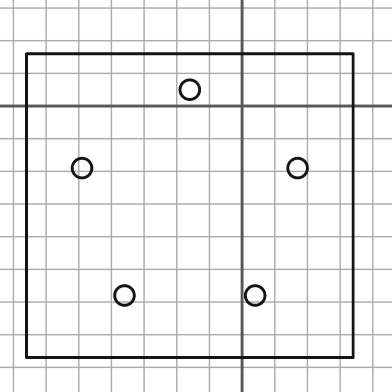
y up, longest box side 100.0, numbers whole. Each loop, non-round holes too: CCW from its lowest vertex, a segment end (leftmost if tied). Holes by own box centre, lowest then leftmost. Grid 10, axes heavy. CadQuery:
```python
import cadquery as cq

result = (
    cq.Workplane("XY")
    .moveTo(-66.0, -77.0)
    .lineTo(34.0, -77.0)
    .lineTo(34.0, 16.0)
    .lineTo(-66.0, 16.0)
    .close()
    .moveTo(-36.0, -58.0)
    .circle(3.0)
    .moveTo(4.0, -58.0)
    .circle(3.0)
    .moveTo(-49.0, -19.0)
    .circle(3.0)
    .moveTo(17.0, -19.0)
    .circle(3.0)
    .moveTo(-16.0, 5.0)
    .circle(3.0)
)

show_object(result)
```